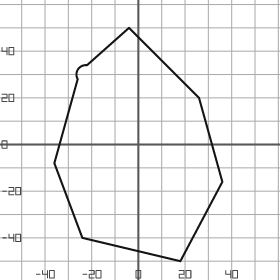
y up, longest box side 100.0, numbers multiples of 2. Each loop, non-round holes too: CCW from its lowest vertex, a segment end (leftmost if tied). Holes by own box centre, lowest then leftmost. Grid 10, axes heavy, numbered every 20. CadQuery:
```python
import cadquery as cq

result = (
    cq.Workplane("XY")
    .moveTo(18.0, -50.0)
    .lineTo(36.0, -16.0)
    .lineTo(26.0, 20.0)
    .lineTo(-4.0, 50.0)
    .lineTo(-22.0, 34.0)
    .threePointArc((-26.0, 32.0), (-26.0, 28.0))
    .lineTo(-36.0, -8.0)
    .lineTo(-24.0, -40.0)
    .close()
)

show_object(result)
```